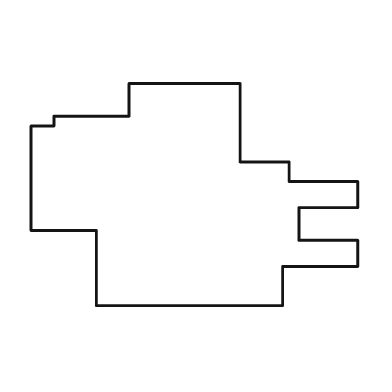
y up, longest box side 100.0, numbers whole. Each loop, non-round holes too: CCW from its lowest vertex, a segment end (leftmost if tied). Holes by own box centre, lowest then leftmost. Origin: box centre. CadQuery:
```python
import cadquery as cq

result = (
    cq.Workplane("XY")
    .moveTo(-30.0, -34.0)
    .lineTo(27.0, -34.0)
    .lineTo(27.0, -22.0)
    .lineTo(50.0, -22.0)
    .lineTo(50.0, -14.0)
    .lineTo(32.0, -14.0)
    .lineTo(32.0, -4.0)
    .lineTo(50.0, -4.0)
    .lineTo(50.0, 4.0)
    .lineTo(29.0, 4.0)
    .lineTo(29.0, 10.0)
    .lineTo(14.0, 10.0)
    .lineTo(14.0, 34.0)
    .lineTo(-20.0, 34.0)
    .lineTo(-20.0, 24.0)
    .lineTo(-43.0, 24.0)
    .lineTo(-43.0, 21.0)
    .lineTo(-50.0, 21.0)
    .lineTo(-50.0, -11.0)
    .lineTo(-30.0, -11.0)
    .close()
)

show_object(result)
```